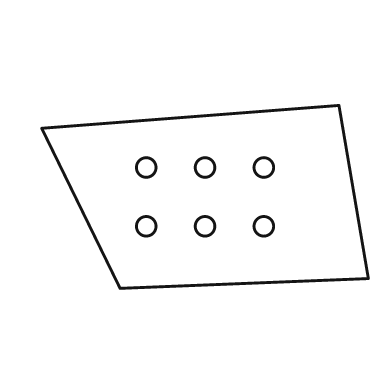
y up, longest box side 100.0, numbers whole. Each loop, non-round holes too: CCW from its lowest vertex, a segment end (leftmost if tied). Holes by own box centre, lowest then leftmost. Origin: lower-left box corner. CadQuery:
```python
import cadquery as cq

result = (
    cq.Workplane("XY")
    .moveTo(24.0, 0.0)
    .lineTo(100.0, 3.0)
    .lineTo(91.0, 56.0)
    .lineTo(0.0, 49.0)
    .close()
    .moveTo(32.0, 19.0)
    .circle(3.0)
    .moveTo(50.0, 19.0)
    .circle(3.0)
    .moveTo(68.0, 19.0)
    .circle(3.0)
    .moveTo(32.0, 37.0)
    .circle(3.0)
    .moveTo(50.0, 37.0)
    .circle(3.0)
    .moveTo(68.0, 37.0)
    .circle(3.0)
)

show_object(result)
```